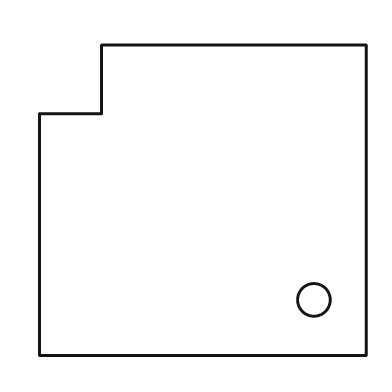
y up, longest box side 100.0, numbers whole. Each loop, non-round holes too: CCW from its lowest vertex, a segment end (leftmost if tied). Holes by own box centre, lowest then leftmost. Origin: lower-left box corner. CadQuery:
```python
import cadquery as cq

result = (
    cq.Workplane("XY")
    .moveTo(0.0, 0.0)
    .lineTo(100.0, 0.0)
    .lineTo(100.0, 95.0)
    .lineTo(19.0, 95.0)
    .lineTo(19.0, 74.0)
    .lineTo(0.0, 74.0)
    .close()
    .moveTo(84.0, 17.0)
    .circle(5.0)
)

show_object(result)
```